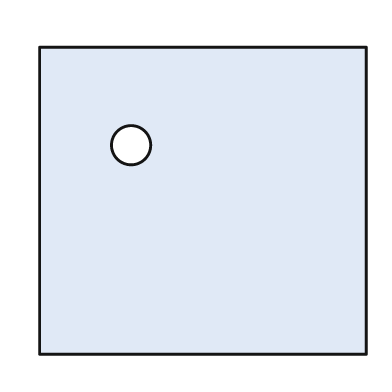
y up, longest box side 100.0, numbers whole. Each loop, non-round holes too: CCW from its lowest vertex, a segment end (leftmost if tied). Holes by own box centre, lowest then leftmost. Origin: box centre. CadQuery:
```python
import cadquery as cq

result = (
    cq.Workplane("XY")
    .moveTo(-50.0, -47.0)
    .lineTo(50.0, -47.0)
    .lineTo(50.0, 47.0)
    .lineTo(-50.0, 47.0)
    .close()
    .moveTo(-22.0, 17.0)
    .circle(6.0)
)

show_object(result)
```